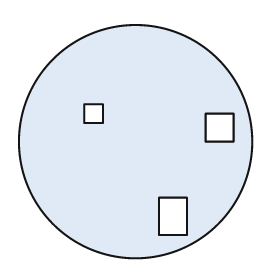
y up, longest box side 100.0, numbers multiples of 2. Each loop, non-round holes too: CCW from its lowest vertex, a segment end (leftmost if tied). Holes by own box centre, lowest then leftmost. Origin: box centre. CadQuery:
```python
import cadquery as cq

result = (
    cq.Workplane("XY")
    .moveTo(0.0, 0.0)
    .circle(50.0)
    .moveTo(10.0, -40.0)
    .lineTo(22.0, -40.0)
    .lineTo(22.0, -24.0)
    .lineTo(10.0, -24.0)
    .close()
    .moveTo(30.0, 0.0)
    .lineTo(42.0, 0.0)
    .lineTo(42.0, 12.0)
    .lineTo(30.0, 12.0)
    .close()
    .moveTo(-22.0, 8.0)
    .lineTo(-14.0, 8.0)
    .lineTo(-14.0, 16.0)
    .lineTo(-22.0, 16.0)
    .close()
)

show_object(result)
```